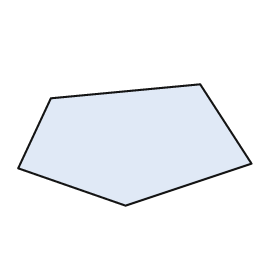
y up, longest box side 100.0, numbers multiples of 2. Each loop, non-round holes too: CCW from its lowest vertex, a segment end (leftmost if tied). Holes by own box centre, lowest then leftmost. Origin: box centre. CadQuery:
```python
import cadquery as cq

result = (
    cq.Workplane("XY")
    .moveTo(-4.0, -26.0)
    .lineTo(50.0, -8.0)
    .lineTo(28.0, 26.0)
    .lineTo(-36.0, 20.0)
    .lineTo(-50.0, -10.0)
    .close()
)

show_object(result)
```